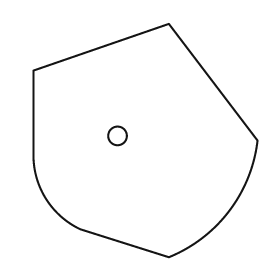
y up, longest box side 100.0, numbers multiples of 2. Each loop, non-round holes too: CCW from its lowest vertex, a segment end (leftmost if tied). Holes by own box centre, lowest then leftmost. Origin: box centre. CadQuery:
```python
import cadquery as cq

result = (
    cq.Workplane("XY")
    .moveTo(10.0, -50.0)
    .threePointArc((36.0, -30.0), (48.0, 0.0))
    .lineTo(10.0, 50.0)
    .lineTo(-48.0, 30.0)
    .lineTo(-48.0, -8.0)
    .threePointArc((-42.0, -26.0), (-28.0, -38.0))
    .close()
    .moveTo(-12.0, 2.0)
    .circle(4.0)
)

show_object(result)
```